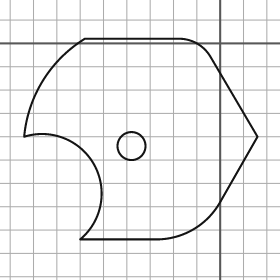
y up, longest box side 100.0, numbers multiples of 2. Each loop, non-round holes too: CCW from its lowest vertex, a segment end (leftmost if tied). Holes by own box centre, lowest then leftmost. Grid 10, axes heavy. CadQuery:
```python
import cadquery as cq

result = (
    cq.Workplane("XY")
    .moveTo(-60.0, -84.0)
    .lineTo(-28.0, -84.0)
    .threePointArc((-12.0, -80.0), (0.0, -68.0))
    .lineTo(16.0, -40.0)
    .lineTo(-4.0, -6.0)
    .threePointArc((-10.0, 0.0), (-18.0, 2.0))
    .lineTo(-58.0, 2.0)
    .threePointArc((-76.0, -16.0), (-84.0, -40.0))
    .threePointArc((-54.0, -52.0), (-60.0, -84.0))
    .close()
    .moveTo(-38.0, -44.0)
    .circle(6.0)
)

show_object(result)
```